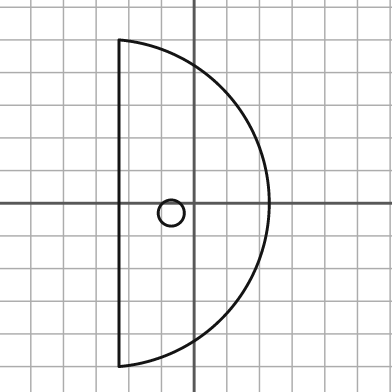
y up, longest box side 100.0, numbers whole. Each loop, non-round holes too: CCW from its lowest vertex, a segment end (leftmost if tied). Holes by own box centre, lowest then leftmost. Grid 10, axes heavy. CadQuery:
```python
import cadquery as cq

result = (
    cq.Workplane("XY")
    .moveTo(-23.0, -50.0)
    .threePointArc((23.0, 0.0), (-23.0, 50.0))
    .close()
    .moveTo(-7.0, -3.0)
    .circle(4.0)
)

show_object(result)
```